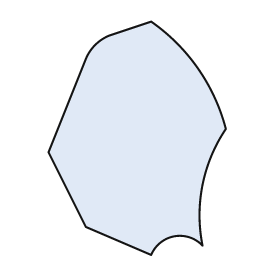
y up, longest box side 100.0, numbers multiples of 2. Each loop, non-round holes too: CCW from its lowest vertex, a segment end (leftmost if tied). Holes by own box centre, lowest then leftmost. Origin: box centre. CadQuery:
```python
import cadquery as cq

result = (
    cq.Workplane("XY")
    .moveTo(6.0, -50.0)
    .threePointArc((16.0, -42.0), (28.0, -46.0))
    .threePointArc((28.0, -20.0), (38.0, 4.0))
    .threePointArc((26.0, 30.0), (6.0, 50.0))
    .lineTo(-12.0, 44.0)
    .threePointArc((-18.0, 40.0), (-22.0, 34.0))
    .lineTo(-38.0, -6.0)
    .lineTo(-22.0, -38.0)
    .close()
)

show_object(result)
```